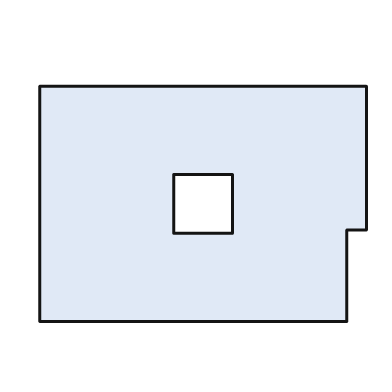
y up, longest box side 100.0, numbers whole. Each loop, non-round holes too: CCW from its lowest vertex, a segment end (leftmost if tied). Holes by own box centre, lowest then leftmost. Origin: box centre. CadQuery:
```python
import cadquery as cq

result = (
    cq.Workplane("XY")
    .moveTo(-50.0, -36.0)
    .lineTo(44.0, -36.0)
    .lineTo(44.0, -8.0)
    .lineTo(50.0, -8.0)
    .lineTo(50.0, 36.0)
    .lineTo(-50.0, 36.0)
    .close()
    .moveTo(-9.0, -9.0)
    .lineTo(9.0, -9.0)
    .lineTo(9.0, 9.0)
    .lineTo(-9.0, 9.0)
    .close()
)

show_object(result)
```